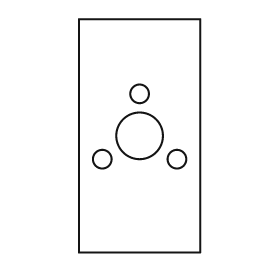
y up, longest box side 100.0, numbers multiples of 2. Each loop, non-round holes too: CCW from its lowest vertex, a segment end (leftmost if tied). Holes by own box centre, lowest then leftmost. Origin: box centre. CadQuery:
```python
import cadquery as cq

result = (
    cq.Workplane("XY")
    .moveTo(-26.0, -50.0)
    .lineTo(26.0, -50.0)
    .lineTo(26.0, 50.0)
    .lineTo(-26.0, 50.0)
    .close()
    .moveTo(-16.0, -10.0)
    .circle(4.0)
    .moveTo(16.0, -10.0)
    .circle(4.0)
    .moveTo(0.0, 0.0)
    .circle(10.0)
    .moveTo(0.0, 18.0)
    .circle(4.0)
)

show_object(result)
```